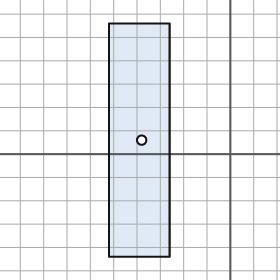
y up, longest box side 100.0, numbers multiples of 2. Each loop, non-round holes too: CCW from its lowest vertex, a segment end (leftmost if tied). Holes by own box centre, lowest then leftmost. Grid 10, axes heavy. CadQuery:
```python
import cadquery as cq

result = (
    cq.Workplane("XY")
    .moveTo(-52.0, -44.0)
    .lineTo(-26.0, -44.0)
    .lineTo(-26.0, 56.0)
    .lineTo(-52.0, 56.0)
    .close()
    .moveTo(-38.0, 6.0)
    .circle(2.0)
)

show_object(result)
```